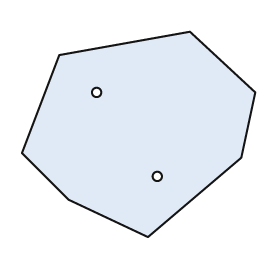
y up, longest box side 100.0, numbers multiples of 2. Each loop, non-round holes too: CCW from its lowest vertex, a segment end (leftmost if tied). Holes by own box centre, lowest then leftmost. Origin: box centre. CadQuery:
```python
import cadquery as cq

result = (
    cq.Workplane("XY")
    .moveTo(4.0, -44.0)
    .lineTo(44.0, -10.0)
    .lineTo(50.0, 18.0)
    .lineTo(22.0, 44.0)
    .lineTo(-34.0, 34.0)
    .lineTo(-50.0, -8.0)
    .lineTo(-30.0, -28.0)
    .close()
    .moveTo(8.0, -18.0)
    .circle(2.0)
    .moveTo(-18.0, 18.0)
    .circle(2.0)
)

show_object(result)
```